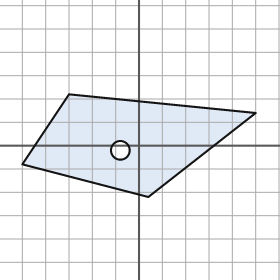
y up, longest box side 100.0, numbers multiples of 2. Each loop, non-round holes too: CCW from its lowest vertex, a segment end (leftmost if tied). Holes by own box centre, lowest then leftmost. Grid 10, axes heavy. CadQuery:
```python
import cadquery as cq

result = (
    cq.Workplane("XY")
    .moveTo(4.0, -22.0)
    .lineTo(50.0, 14.0)
    .lineTo(-30.0, 22.0)
    .lineTo(-50.0, -8.0)
    .close()
    .moveTo(-8.0, -2.0)
    .circle(4.0)
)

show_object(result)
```